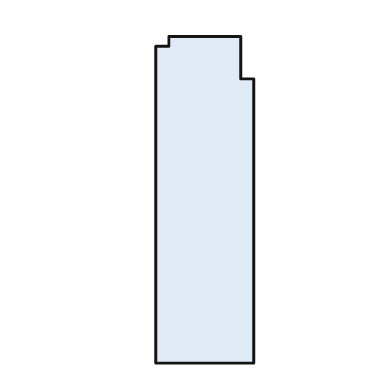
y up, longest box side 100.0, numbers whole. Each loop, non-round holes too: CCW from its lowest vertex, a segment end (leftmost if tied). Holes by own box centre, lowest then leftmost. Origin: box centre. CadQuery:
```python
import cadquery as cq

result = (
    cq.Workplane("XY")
    .moveTo(-15.0, -50.0)
    .lineTo(15.0, -50.0)
    .lineTo(15.0, 37.0)
    .lineTo(11.0, 37.0)
    .lineTo(11.0, 50.0)
    .lineTo(-11.0, 50.0)
    .lineTo(-11.0, 47.0)
    .lineTo(-15.0, 47.0)
    .close()
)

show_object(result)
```